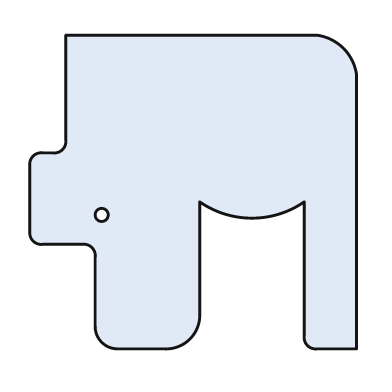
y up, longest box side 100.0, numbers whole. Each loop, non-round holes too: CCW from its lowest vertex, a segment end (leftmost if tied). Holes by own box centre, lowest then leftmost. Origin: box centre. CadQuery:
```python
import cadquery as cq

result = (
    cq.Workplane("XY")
    .moveTo(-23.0, -48.0)
    .lineTo(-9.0, -48.0)
    .threePointArc((-1.0, -45.0), (2.0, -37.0))
    .lineTo(2.0, -3.0)
    .threePointArc((18.0, -8.0), (34.0, -3.0))
    .lineTo(34.0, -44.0)
    .threePointArc((35.0, -47.0), (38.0, -48.0))
    .lineTo(50.0, -48.0)
    .lineTo(50.0, 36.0)
    .threePointArc((46.0, 44.0), (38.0, 48.0))
    .lineTo(-39.0, 48.0)
    .lineTo(-39.0, 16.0)
    .threePointArc((-40.0, 13.0), (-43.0, 12.0))
    .lineTo(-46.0, 12.0)
    .threePointArc((-49.0, 11.0), (-50.0, 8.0))
    .lineTo(-50.0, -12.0)
    .threePointArc((-49.0, -15.0), (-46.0, -16.0))
    .lineTo(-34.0, -16.0)
    .threePointArc((-31.0, -17.0), (-30.0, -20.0))
    .lineTo(-30.0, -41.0)
    .threePointArc((-28.0, -46.0), (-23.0, -48.0))
    .close()
    .moveTo(-28.0, -7.0)
    .circle(2.0)
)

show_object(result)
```